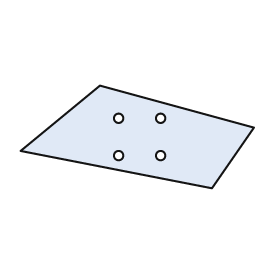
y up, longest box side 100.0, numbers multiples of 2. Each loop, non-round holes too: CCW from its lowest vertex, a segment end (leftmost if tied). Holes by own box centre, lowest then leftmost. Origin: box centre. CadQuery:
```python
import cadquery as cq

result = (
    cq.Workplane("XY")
    .moveTo(32.0, -22.0)
    .lineTo(50.0, 4.0)
    .lineTo(-16.0, 22.0)
    .lineTo(-50.0, -6.0)
    .close()
    .moveTo(-8.0, -8.0)
    .circle(2.0)
    .moveTo(10.0, -8.0)
    .circle(2.0)
    .moveTo(-8.0, 8.0)
    .circle(2.0)
    .moveTo(10.0, 8.0)
    .circle(2.0)
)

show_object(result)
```